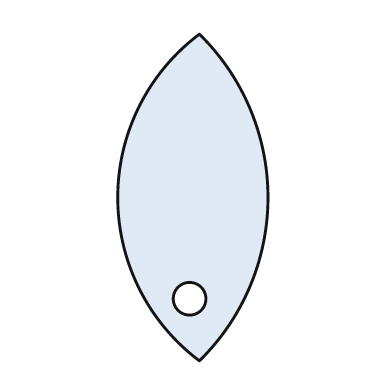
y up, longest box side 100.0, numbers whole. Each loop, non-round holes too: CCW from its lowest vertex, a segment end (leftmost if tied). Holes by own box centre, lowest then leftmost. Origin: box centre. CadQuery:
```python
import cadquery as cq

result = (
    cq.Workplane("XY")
    .moveTo(2.0, -50.0)
    .threePointArc((23.0, 0.0), (2.0, 50.0))
    .threePointArc((-23.0, 0.0), (2.0, -50.0))
    .close()
    .moveTo(-1.0, -31.0)
    .circle(5.0)
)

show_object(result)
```